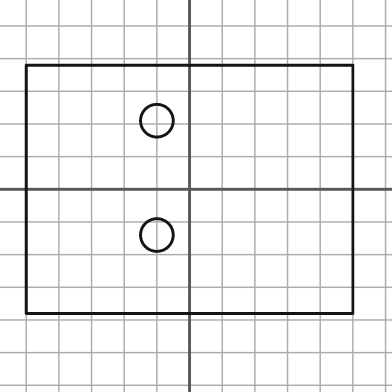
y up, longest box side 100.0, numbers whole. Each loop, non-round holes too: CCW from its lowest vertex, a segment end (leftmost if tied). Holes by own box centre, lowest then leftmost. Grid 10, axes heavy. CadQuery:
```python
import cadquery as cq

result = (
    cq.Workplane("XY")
    .moveTo(-50.0, -38.0)
    .lineTo(50.0, -38.0)
    .lineTo(50.0, 38.0)
    .lineTo(-50.0, 38.0)
    .close()
    .moveTo(-10.0, -14.0)
    .circle(5.0)
    .moveTo(-10.0, 21.0)
    .circle(5.0)
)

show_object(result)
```